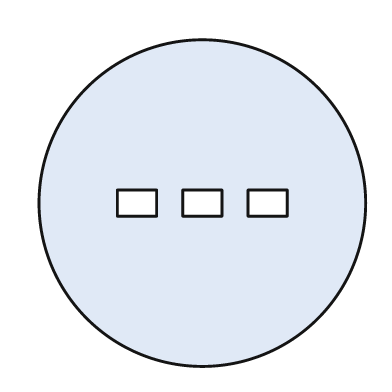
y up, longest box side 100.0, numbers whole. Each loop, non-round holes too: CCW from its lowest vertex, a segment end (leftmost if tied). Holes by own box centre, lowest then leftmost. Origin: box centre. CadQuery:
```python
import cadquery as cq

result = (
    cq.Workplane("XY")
    .moveTo(0.0, 0.0)
    .circle(50.0)
    .moveTo(-26.0, -4.0)
    .lineTo(-14.0, -4.0)
    .lineTo(-14.0, 4.0)
    .lineTo(-26.0, 4.0)
    .close()
    .moveTo(-6.0, -4.0)
    .lineTo(6.0, -4.0)
    .lineTo(6.0, 4.0)
    .lineTo(-6.0, 4.0)
    .close()
    .moveTo(14.0, -4.0)
    .lineTo(26.0, -4.0)
    .lineTo(26.0, 4.0)
    .lineTo(14.0, 4.0)
    .close()
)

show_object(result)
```